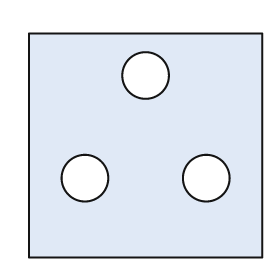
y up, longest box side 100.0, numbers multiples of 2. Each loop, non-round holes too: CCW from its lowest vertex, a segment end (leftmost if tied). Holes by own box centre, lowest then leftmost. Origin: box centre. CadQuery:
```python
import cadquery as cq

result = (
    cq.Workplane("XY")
    .moveTo(-50.0, -48.0)
    .lineTo(50.0, -48.0)
    .lineTo(50.0, 48.0)
    .lineTo(-50.0, 48.0)
    .close()
    .moveTo(-26.0, -14.0)
    .circle(10.0)
    .moveTo(26.0, -14.0)
    .circle(10.0)
    .moveTo(0.0, 30.0)
    .circle(10.0)
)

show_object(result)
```